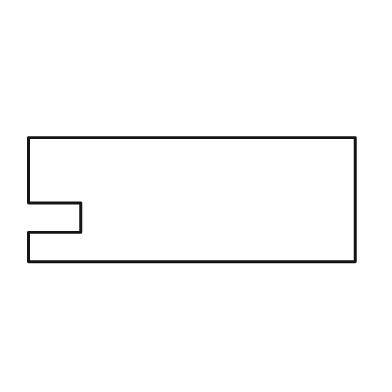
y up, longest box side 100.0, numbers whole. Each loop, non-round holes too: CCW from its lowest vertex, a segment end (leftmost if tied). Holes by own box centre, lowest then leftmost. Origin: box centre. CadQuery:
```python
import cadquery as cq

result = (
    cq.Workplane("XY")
    .moveTo(-50.0, -19.0)
    .lineTo(50.0, -19.0)
    .lineTo(50.0, 19.0)
    .lineTo(-50.0, 19.0)
    .lineTo(-50.0, -1.0)
    .lineTo(-34.0, -1.0)
    .lineTo(-34.0, -10.0)
    .lineTo(-50.0, -10.0)
    .close()
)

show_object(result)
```